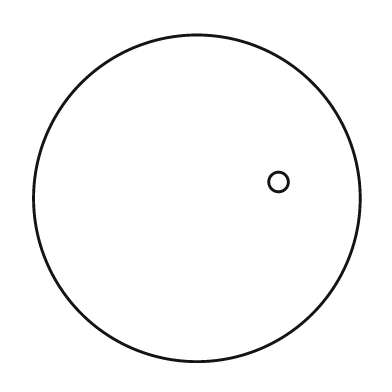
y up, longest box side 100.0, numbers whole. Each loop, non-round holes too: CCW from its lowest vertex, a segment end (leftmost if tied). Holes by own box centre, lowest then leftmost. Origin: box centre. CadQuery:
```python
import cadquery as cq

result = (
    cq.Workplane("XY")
    .moveTo(0.0, 0.0)
    .circle(50.0)
    .moveTo(25.0, 5.0)
    .circle(3.0)
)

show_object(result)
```